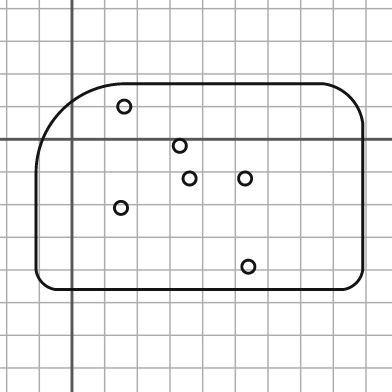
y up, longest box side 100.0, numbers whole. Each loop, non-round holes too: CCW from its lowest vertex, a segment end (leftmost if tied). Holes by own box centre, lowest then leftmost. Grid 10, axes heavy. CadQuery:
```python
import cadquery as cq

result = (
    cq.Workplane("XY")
    .moveTo(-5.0, -46.0)
    .lineTo(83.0, -46.0)
    .threePointArc((87.0, -44.0), (89.0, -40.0))
    .lineTo(89.0, 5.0)
    .threePointArc((85.0, 13.0), (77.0, 17.0))
    .lineTo(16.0, 17.0)
    .threePointArc((-3.0, 9.0), (-11.0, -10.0))
    .lineTo(-11.0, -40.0)
    .threePointArc((-9.0, -44.0), (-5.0, -46.0))
    .close()
    .moveTo(54.0, -39.0)
    .circle(2.0)
    .moveTo(15.0, -21.0)
    .circle(2.0)
    .moveTo(36.0, -12.0)
    .circle(2.0)
    .moveTo(53.0, -12.0)
    .circle(2.0)
    .moveTo(33.0, -2.0)
    .circle(2.0)
    .moveTo(16.0, 10.0)
    .circle(2.0)
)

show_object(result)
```